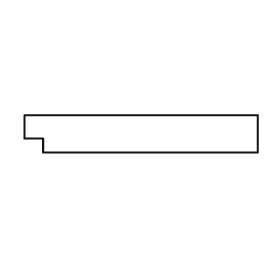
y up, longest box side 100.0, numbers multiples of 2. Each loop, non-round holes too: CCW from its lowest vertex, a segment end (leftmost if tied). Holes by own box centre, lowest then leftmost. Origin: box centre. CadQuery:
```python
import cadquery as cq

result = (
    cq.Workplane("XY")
    .moveTo(-42.0, -8.0)
    .lineTo(50.0, -8.0)
    .lineTo(50.0, 8.0)
    .lineTo(-50.0, 8.0)
    .lineTo(-50.0, -2.0)
    .lineTo(-42.0, -2.0)
    .close()
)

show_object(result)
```